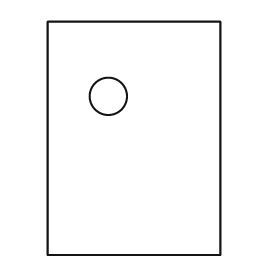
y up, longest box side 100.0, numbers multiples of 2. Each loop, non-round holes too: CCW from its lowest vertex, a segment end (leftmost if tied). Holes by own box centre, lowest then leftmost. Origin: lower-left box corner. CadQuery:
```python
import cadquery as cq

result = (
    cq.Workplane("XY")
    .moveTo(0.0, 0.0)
    .lineTo(74.0, 0.0)
    .lineTo(74.0, 100.0)
    .lineTo(0.0, 100.0)
    .close()
    .moveTo(26.0, 68.0)
    .circle(8.0)
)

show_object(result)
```